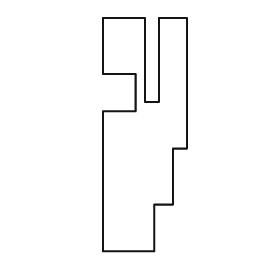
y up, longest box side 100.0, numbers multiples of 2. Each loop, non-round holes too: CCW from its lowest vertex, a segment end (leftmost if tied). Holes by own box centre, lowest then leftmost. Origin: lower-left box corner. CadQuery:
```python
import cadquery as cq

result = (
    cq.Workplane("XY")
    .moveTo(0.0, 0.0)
    .lineTo(22.0, 0.0)
    .lineTo(22.0, 20.0)
    .lineTo(30.0, 20.0)
    .lineTo(30.0, 44.0)
    .lineTo(36.0, 44.0)
    .lineTo(36.0, 100.0)
    .lineTo(24.0, 100.0)
    .lineTo(24.0, 64.0)
    .lineTo(18.0, 64.0)
    .lineTo(18.0, 100.0)
    .lineTo(0.0, 100.0)
    .lineTo(0.0, 76.0)
    .lineTo(14.0, 76.0)
    .lineTo(14.0, 60.0)
    .lineTo(0.0, 60.0)
    .close()
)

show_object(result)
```